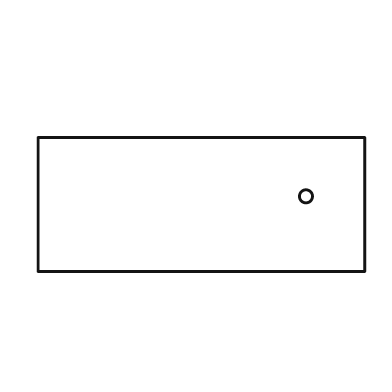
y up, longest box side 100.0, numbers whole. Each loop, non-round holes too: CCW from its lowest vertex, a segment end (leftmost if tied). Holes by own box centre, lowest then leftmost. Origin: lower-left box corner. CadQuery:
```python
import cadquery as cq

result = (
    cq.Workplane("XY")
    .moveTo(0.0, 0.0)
    .lineTo(100.0, 0.0)
    .lineTo(100.0, 41.0)
    .lineTo(0.0, 41.0)
    .close()
    .moveTo(82.0, 23.0)
    .circle(2.0)
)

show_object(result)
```